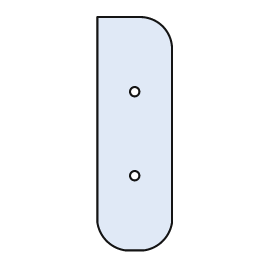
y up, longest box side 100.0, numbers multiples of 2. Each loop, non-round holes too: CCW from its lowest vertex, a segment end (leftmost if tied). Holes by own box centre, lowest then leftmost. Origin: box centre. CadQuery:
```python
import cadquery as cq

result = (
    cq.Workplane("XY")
    .moveTo(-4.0, -50.0)
    .lineTo(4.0, -50.0)
    .threePointArc((12.0, -46.0), (16.0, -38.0))
    .lineTo(16.0, 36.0)
    .threePointArc((12.0, 46.0), (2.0, 50.0))
    .lineTo(-16.0, 50.0)
    .lineTo(-16.0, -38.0)
    .threePointArc((-12.0, -46.0), (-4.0, -50.0))
    .close()
    .moveTo(0.0, -18.0)
    .circle(2.0)
    .moveTo(0.0, 18.0)
    .circle(2.0)
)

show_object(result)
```